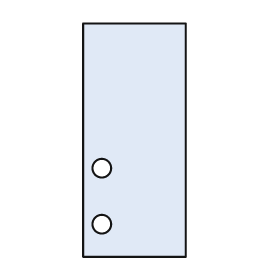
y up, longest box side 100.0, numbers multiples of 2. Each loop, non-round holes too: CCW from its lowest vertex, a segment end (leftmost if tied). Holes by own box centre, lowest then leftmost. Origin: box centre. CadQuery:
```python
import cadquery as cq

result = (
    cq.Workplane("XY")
    .moveTo(-22.0, -50.0)
    .lineTo(22.0, -50.0)
    .lineTo(22.0, 50.0)
    .lineTo(-22.0, 50.0)
    .close()
    .moveTo(-14.0, -36.0)
    .circle(4.0)
    .moveTo(-14.0, -12.0)
    .circle(4.0)
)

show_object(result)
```